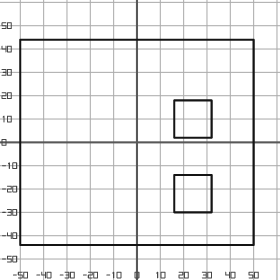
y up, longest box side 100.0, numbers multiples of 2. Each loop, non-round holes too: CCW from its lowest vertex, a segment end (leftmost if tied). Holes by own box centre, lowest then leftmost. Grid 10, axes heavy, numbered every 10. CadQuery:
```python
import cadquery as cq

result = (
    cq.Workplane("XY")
    .moveTo(-50.0, -44.0)
    .lineTo(50.0, -44.0)
    .lineTo(50.0, 44.0)
    .lineTo(-50.0, 44.0)
    .close()
    .moveTo(16.0, -30.0)
    .lineTo(32.0, -30.0)
    .lineTo(32.0, -14.0)
    .lineTo(16.0, -14.0)
    .close()
    .moveTo(16.0, 2.0)
    .lineTo(32.0, 2.0)
    .lineTo(32.0, 18.0)
    .lineTo(16.0, 18.0)
    .close()
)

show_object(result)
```